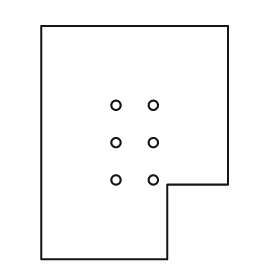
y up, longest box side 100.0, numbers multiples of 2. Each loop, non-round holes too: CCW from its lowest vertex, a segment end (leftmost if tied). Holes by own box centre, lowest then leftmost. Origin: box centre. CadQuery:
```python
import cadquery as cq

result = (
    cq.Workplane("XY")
    .moveTo(-40.0, -50.0)
    .lineTo(14.0, -50.0)
    .lineTo(14.0, -18.0)
    .lineTo(40.0, -18.0)
    .lineTo(40.0, 50.0)
    .lineTo(-40.0, 50.0)
    .close()
    .moveTo(-8.0, -16.0)
    .circle(2.0)
    .moveTo(8.0, -16.0)
    .circle(2.0)
    .moveTo(-8.0, 0.0)
    .circle(2.0)
    .moveTo(8.0, 0.0)
    .circle(2.0)
    .moveTo(-8.0, 16.0)
    .circle(2.0)
    .moveTo(8.0, 16.0)
    .circle(2.0)
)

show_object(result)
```